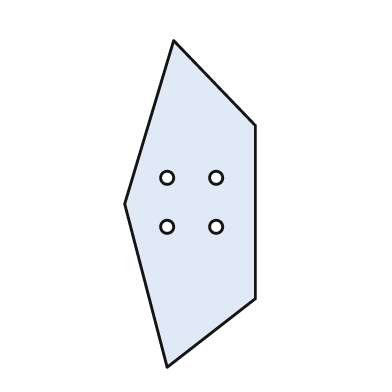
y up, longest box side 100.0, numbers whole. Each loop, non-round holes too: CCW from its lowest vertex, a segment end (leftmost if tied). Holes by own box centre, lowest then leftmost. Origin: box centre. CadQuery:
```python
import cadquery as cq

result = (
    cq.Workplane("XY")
    .moveTo(-7.0, -50.0)
    .lineTo(20.0, -29.0)
    .lineTo(20.0, 24.0)
    .lineTo(-5.0, 50.0)
    .lineTo(-20.0, 0.0)
    .close()
    .moveTo(-7.0, -7.0)
    .circle(2.0)
    .moveTo(8.0, -7.0)
    .circle(2.0)
    .moveTo(-7.0, 8.0)
    .circle(2.0)
    .moveTo(8.0, 8.0)
    .circle(2.0)
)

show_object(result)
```